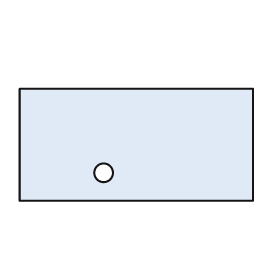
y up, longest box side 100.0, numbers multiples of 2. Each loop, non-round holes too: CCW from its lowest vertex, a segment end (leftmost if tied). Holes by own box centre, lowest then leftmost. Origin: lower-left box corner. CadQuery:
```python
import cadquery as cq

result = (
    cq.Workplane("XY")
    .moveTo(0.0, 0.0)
    .lineTo(100.0, 0.0)
    .lineTo(100.0, 48.0)
    .lineTo(0.0, 48.0)
    .close()
    .moveTo(36.0, 12.0)
    .circle(4.0)
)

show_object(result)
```